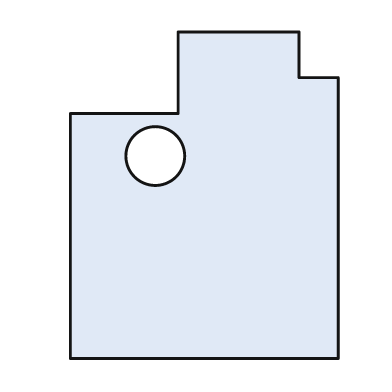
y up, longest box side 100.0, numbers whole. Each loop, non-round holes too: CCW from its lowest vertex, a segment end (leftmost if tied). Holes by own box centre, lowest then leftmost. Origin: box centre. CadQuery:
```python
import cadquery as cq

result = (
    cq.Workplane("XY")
    .moveTo(-41.0, -50.0)
    .lineTo(41.0, -50.0)
    .lineTo(41.0, 36.0)
    .lineTo(29.0, 36.0)
    .lineTo(29.0, 50.0)
    .lineTo(-8.0, 50.0)
    .lineTo(-8.0, 25.0)
    .lineTo(-41.0, 25.0)
    .close()
    .moveTo(-15.0, 12.0)
    .circle(9.0)
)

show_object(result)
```